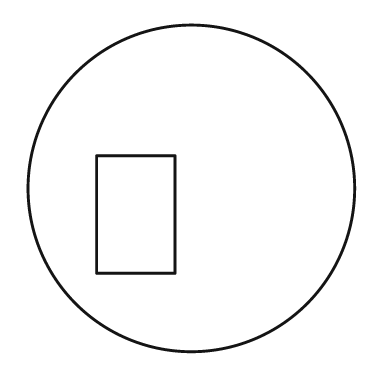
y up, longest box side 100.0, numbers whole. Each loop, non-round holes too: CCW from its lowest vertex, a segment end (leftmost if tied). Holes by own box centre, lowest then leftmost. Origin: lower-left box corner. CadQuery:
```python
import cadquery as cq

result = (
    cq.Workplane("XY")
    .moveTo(50.0, 50.0)
    .circle(50.0)
    .moveTo(21.0, 24.0)
    .lineTo(45.0, 24.0)
    .lineTo(45.0, 60.0)
    .lineTo(21.0, 60.0)
    .close()
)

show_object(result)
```